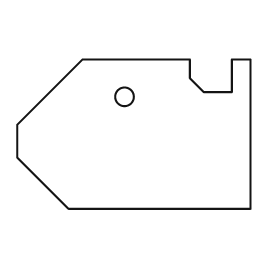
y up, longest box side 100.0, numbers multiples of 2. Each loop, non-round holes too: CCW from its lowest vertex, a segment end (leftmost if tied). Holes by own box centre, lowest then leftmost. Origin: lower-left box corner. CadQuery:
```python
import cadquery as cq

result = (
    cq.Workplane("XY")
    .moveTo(22.0, 0.0)
    .lineTo(100.0, 0.0)
    .lineTo(100.0, 64.0)
    .lineTo(92.0, 64.0)
    .lineTo(92.0, 50.0)
    .lineTo(80.0, 50.0)
    .lineTo(74.0, 56.0)
    .lineTo(74.0, 64.0)
    .lineTo(28.0, 64.0)
    .lineTo(0.0, 36.0)
    .lineTo(0.0, 22.0)
    .close()
    .moveTo(46.0, 48.0)
    .circle(4.0)
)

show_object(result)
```